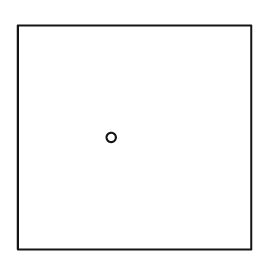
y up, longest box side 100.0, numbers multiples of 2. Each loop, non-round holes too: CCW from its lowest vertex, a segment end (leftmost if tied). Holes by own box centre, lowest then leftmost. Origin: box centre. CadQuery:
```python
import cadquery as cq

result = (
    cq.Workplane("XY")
    .moveTo(-50.0, -48.0)
    .lineTo(50.0, -48.0)
    .lineTo(50.0, 48.0)
    .lineTo(-50.0, 48.0)
    .close()
    .moveTo(-10.0, 0.0)
    .circle(2.0)
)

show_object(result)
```